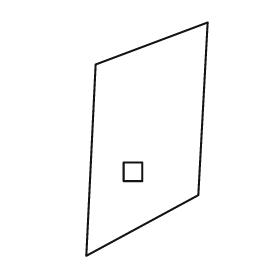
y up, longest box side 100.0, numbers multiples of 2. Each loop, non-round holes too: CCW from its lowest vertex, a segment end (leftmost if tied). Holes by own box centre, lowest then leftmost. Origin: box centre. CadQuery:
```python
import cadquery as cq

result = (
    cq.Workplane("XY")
    .moveTo(-26.0, -50.0)
    .lineTo(22.0, -24.0)
    .lineTo(26.0, 50.0)
    .lineTo(-22.0, 32.0)
    .close()
    .moveTo(-10.0, -18.0)
    .lineTo(-2.0, -18.0)
    .lineTo(-2.0, -10.0)
    .lineTo(-10.0, -10.0)
    .close()
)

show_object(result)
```